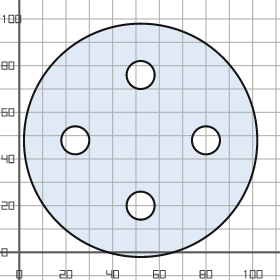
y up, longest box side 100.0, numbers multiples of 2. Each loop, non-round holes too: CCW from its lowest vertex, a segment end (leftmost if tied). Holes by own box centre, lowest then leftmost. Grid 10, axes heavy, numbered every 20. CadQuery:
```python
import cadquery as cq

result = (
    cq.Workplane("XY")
    .moveTo(52.0, 48.0)
    .circle(50.0)
    .moveTo(52.0, 20.0)
    .circle(6.0)
    .moveTo(24.0, 48.0)
    .circle(6.0)
    .moveTo(80.0, 48.0)
    .circle(6.0)
    .moveTo(52.0, 76.0)
    .circle(6.0)
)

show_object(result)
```